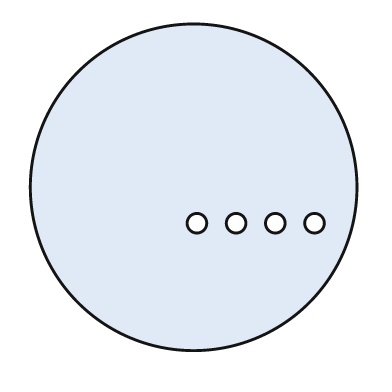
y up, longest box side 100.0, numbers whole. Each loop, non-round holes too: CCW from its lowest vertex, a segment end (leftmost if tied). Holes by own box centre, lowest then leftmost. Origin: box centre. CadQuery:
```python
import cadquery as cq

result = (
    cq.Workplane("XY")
    .moveTo(0.0, 0.0)
    .circle(50.0)
    .moveTo(1.0, -11.0)
    .circle(3.0)
    .moveTo(13.0, -11.0)
    .circle(3.0)
    .moveTo(25.0, -11.0)
    .circle(3.0)
    .moveTo(37.0, -11.0)
    .circle(3.0)
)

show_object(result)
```